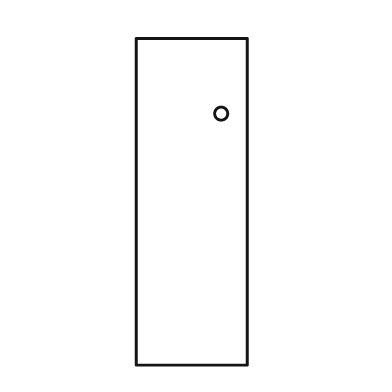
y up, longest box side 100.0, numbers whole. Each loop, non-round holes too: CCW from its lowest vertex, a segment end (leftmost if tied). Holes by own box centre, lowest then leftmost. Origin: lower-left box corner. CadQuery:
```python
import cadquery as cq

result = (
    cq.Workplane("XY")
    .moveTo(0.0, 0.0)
    .lineTo(34.0, 0.0)
    .lineTo(34.0, 100.0)
    .lineTo(0.0, 100.0)
    .close()
    .moveTo(26.0, 77.0)
    .circle(2.0)
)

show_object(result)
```